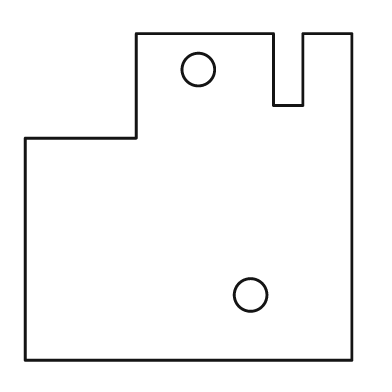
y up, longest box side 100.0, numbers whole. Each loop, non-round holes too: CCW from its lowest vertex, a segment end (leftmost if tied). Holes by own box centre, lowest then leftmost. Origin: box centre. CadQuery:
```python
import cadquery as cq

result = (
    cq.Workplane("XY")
    .moveTo(-50.0, -50.0)
    .lineTo(50.0, -50.0)
    .lineTo(50.0, 50.0)
    .lineTo(35.0, 50.0)
    .lineTo(35.0, 28.0)
    .lineTo(26.0, 28.0)
    .lineTo(26.0, 50.0)
    .lineTo(-16.0, 50.0)
    .lineTo(-16.0, 18.0)
    .lineTo(-50.0, 18.0)
    .close()
    .moveTo(19.0, -30.0)
    .circle(5.0)
    .moveTo(3.0, 39.0)
    .circle(5.0)
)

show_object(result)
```